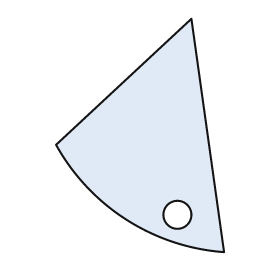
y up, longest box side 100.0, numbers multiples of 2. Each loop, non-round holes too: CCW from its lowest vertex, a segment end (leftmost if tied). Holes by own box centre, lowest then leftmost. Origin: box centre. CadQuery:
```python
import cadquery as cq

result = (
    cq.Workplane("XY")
    .moveTo(36.0, -50.0)
    .lineTo(22.0, 50.0)
    .lineTo(-36.0, -4.0)
    .threePointArc((-6.0, -36.0), (36.0, -50.0))
    .close()
    .moveTo(16.0, -34.0)
    .circle(6.0)
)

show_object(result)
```